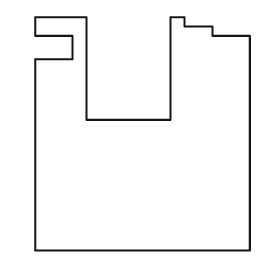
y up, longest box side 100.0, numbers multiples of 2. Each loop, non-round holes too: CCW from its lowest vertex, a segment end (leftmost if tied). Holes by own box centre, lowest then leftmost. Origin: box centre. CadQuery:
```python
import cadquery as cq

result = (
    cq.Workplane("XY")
    .moveTo(-46.0, -50.0)
    .lineTo(46.0, -50.0)
    .lineTo(46.0, 42.0)
    .lineTo(30.0, 42.0)
    .lineTo(30.0, 46.0)
    .lineTo(18.0, 46.0)
    .lineTo(18.0, 50.0)
    .lineTo(12.0, 50.0)
    .lineTo(12.0, 6.0)
    .lineTo(-24.0, 6.0)
    .lineTo(-24.0, 50.0)
    .lineTo(-46.0, 50.0)
    .lineTo(-46.0, 42.0)
    .lineTo(-30.0, 42.0)
    .lineTo(-30.0, 32.0)
    .lineTo(-46.0, 32.0)
    .close()
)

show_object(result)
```